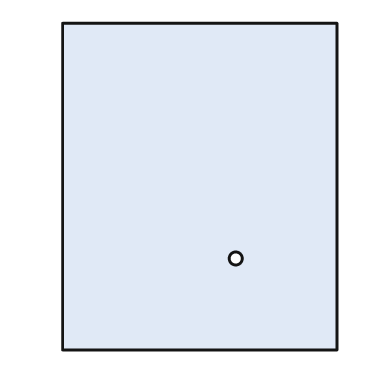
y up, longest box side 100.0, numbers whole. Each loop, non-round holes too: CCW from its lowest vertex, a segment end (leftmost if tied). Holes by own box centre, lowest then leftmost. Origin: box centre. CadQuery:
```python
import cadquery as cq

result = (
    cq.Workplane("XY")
    .moveTo(-42.0, -50.0)
    .lineTo(42.0, -50.0)
    .lineTo(42.0, 50.0)
    .lineTo(-42.0, 50.0)
    .close()
    .moveTo(11.0, -22.0)
    .circle(2.0)
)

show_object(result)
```